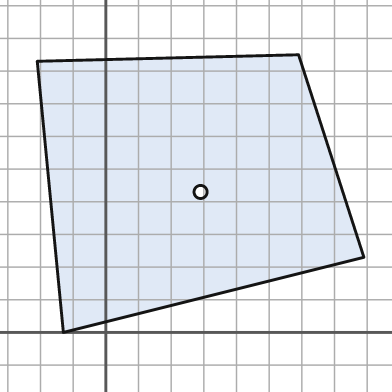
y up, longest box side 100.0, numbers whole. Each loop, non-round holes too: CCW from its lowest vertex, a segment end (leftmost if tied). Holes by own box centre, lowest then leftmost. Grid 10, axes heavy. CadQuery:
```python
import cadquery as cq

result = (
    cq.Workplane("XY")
    .moveTo(-13.0, 0.0)
    .lineTo(79.0, 23.0)
    .lineTo(59.0, 85.0)
    .lineTo(-21.0, 83.0)
    .close()
    .moveTo(29.0, 43.0)
    .circle(2.0)
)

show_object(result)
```